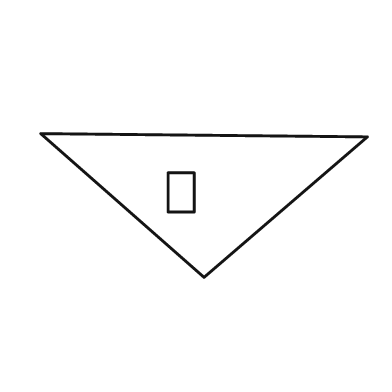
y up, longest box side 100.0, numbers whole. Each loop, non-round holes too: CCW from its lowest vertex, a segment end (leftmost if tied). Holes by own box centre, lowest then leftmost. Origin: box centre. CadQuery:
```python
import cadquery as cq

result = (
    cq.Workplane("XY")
    .moveTo(0.0, -22.0)
    .lineTo(50.0, 21.0)
    .lineTo(-50.0, 22.0)
    .close()
    .moveTo(-11.0, -2.0)
    .lineTo(-3.0, -2.0)
    .lineTo(-3.0, 10.0)
    .lineTo(-11.0, 10.0)
    .close()
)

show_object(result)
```